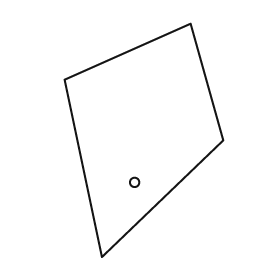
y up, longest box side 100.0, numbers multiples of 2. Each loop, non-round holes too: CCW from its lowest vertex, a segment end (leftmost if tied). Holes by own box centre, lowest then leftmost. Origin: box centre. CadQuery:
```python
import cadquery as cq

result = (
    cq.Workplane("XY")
    .moveTo(-18.0, -50.0)
    .lineTo(34.0, 0.0)
    .lineTo(20.0, 50.0)
    .lineTo(-34.0, 26.0)
    .close()
    .moveTo(-4.0, -18.0)
    .circle(2.0)
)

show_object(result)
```